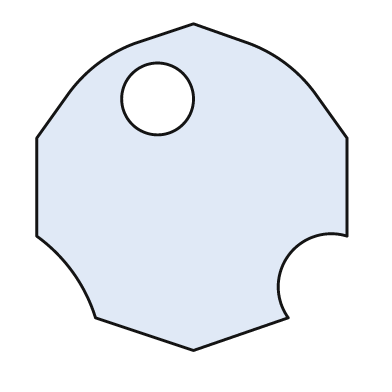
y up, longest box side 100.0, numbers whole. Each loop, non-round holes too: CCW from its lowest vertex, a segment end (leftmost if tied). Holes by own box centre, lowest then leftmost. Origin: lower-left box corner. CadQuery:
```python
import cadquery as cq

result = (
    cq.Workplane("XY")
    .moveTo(48.0, 0.0)
    .lineTo(77.0, 10.0)
    .threePointArc((77.0, 29.0), (95.0, 35.0))
    .lineTo(95.0, 65.0)
    .lineTo(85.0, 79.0)
    .threePointArc((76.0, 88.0), (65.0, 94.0))
    .lineTo(48.0, 100.0)
    .lineTo(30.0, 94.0)
    .threePointArc((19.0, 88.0), (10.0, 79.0))
    .lineTo(0.0, 65.0)
    .lineTo(0.0, 35.0)
    .threePointArc((11.0, 24.0), (18.0, 10.0))
    .close()
    .moveTo(37.0, 77.0)
    .circle(11.0)
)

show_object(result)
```